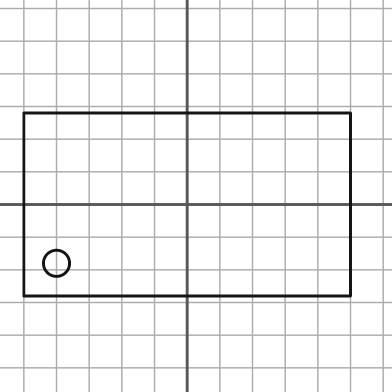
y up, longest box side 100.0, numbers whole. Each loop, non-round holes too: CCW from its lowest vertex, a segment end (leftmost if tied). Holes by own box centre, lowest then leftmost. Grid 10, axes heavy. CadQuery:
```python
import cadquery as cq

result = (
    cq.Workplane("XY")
    .moveTo(-50.0, -28.0)
    .lineTo(50.0, -28.0)
    .lineTo(50.0, 28.0)
    .lineTo(-50.0, 28.0)
    .close()
    .moveTo(-40.0, -18.0)
    .circle(4.0)
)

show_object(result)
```